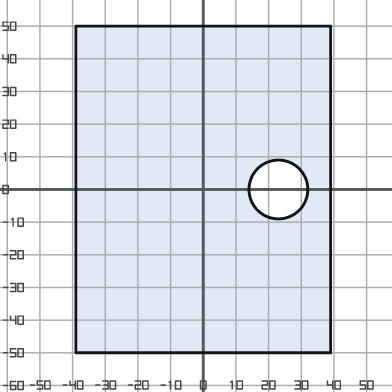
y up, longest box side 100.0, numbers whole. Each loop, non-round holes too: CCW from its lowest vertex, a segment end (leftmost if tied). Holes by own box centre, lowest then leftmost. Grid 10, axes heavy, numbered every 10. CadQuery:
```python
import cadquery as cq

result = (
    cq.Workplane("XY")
    .moveTo(-39.0, -50.0)
    .lineTo(39.0, -50.0)
    .lineTo(39.0, 50.0)
    .lineTo(-39.0, 50.0)
    .close()
    .moveTo(23.0, 0.0)
    .circle(9.0)
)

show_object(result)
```